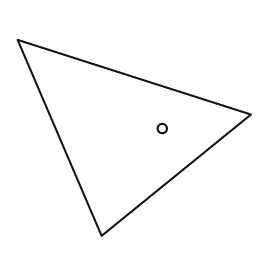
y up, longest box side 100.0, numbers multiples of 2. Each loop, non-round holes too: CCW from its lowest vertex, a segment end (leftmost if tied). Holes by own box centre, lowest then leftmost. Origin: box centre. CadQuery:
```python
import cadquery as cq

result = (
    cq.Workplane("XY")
    .moveTo(-14.0, -42.0)
    .lineTo(50.0, 10.0)
    .lineTo(-50.0, 42.0)
    .close()
    .moveTo(12.0, 4.0)
    .circle(2.0)
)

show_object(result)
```